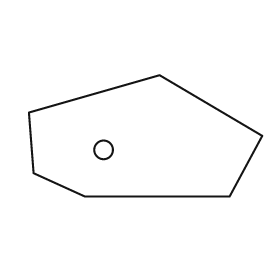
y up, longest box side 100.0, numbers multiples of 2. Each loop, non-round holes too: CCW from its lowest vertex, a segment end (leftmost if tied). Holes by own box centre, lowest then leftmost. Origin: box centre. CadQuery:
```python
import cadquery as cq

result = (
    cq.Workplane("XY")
    .moveTo(-26.0, -26.0)
    .lineTo(36.0, -26.0)
    .lineTo(50.0, 0.0)
    .lineTo(6.0, 26.0)
    .lineTo(-50.0, 10.0)
    .lineTo(-48.0, -16.0)
    .close()
    .moveTo(-18.0, -6.0)
    .circle(4.0)
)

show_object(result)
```